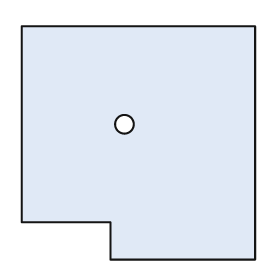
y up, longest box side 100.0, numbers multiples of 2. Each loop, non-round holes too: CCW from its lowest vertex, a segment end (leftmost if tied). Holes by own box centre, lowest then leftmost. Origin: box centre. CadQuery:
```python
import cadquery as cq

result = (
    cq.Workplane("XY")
    .moveTo(-12.0, -50.0)
    .lineTo(50.0, -50.0)
    .lineTo(50.0, 50.0)
    .lineTo(-50.0, 50.0)
    .lineTo(-50.0, -34.0)
    .lineTo(-12.0, -34.0)
    .close()
    .moveTo(-6.0, 8.0)
    .circle(4.0)
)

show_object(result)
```